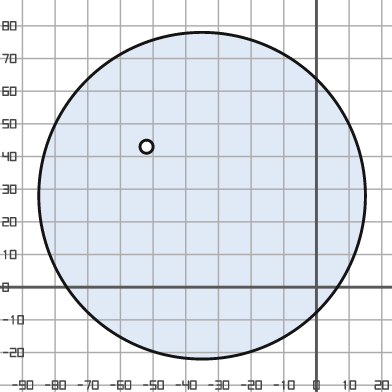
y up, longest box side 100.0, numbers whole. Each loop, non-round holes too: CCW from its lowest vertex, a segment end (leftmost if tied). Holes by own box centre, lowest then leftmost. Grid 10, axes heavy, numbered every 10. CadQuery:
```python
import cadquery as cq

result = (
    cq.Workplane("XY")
    .moveTo(-35.0, 28.0)
    .circle(50.0)
    .moveTo(-52.0, 43.0)
    .circle(2.0)
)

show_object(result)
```